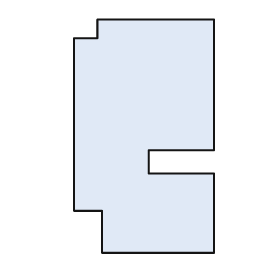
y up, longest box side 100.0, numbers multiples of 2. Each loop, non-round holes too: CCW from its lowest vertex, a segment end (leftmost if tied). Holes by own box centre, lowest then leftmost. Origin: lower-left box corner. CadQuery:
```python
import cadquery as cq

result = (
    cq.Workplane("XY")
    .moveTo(12.0, 0.0)
    .lineTo(60.0, 0.0)
    .lineTo(60.0, 34.0)
    .lineTo(32.0, 34.0)
    .lineTo(32.0, 44.0)
    .lineTo(60.0, 44.0)
    .lineTo(60.0, 100.0)
    .lineTo(10.0, 100.0)
    .lineTo(10.0, 92.0)
    .lineTo(0.0, 92.0)
    .lineTo(0.0, 18.0)
    .lineTo(12.0, 18.0)
    .close()
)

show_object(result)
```